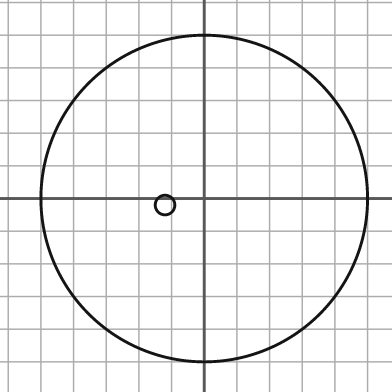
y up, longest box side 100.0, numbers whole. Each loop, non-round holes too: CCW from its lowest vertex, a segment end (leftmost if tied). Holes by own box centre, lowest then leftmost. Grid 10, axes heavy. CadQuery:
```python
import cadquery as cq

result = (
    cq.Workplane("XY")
    .moveTo(0.0, 0.0)
    .circle(50.0)
    .moveTo(-12.0, -2.0)
    .circle(3.0)
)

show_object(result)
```